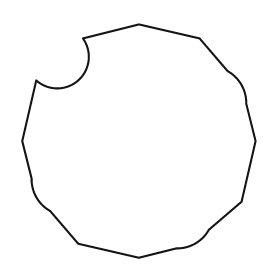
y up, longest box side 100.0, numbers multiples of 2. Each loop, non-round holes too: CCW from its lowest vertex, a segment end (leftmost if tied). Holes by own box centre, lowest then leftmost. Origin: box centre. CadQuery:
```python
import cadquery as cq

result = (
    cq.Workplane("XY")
    .moveTo(0.0, -50.0)
    .lineTo(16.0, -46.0)
    .threePointArc((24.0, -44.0), (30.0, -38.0))
    .lineTo(44.0, -26.0)
    .lineTo(50.0, 0.0)
    .lineTo(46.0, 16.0)
    .threePointArc((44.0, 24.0), (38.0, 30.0))
    .lineTo(26.0, 44.0)
    .lineTo(0.0, 50.0)
    .lineTo(-24.0, 44.0)
    .threePointArc((-26.0, 26.0), (-44.0, 26.0))
    .lineTo(-50.0, 0.0)
    .lineTo(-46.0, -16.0)
    .threePointArc((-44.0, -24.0), (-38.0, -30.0))
    .lineTo(-26.0, -44.0)
    .close()
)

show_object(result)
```